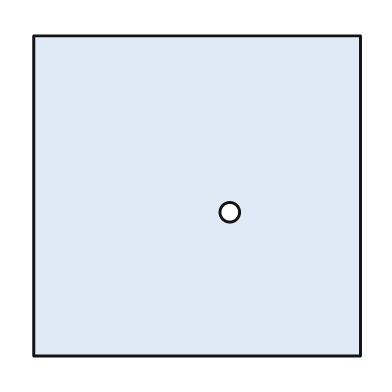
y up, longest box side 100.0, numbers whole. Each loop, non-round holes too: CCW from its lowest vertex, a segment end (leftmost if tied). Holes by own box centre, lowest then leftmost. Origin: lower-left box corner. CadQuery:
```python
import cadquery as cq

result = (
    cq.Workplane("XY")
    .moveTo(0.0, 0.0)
    .lineTo(100.0, 0.0)
    .lineTo(100.0, 98.0)
    .lineTo(0.0, 98.0)
    .close()
    .moveTo(60.0, 44.0)
    .circle(3.0)
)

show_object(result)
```